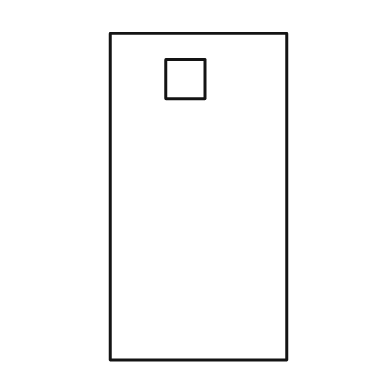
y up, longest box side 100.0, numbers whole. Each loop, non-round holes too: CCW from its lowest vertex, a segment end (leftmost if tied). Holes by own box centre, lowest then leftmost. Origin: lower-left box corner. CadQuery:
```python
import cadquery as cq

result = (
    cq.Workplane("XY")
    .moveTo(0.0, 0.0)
    .lineTo(54.0, 0.0)
    .lineTo(54.0, 100.0)
    .lineTo(0.0, 100.0)
    .close()
    .moveTo(17.0, 80.0)
    .lineTo(29.0, 80.0)
    .lineTo(29.0, 92.0)
    .lineTo(17.0, 92.0)
    .close()
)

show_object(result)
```